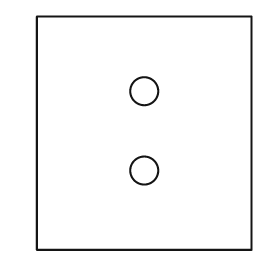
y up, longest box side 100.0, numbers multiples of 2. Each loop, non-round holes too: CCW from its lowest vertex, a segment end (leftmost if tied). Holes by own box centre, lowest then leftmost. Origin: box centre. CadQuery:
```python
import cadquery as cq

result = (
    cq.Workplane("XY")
    .moveTo(-46.0, -50.0)
    .lineTo(46.0, -50.0)
    .lineTo(46.0, 50.0)
    .lineTo(-46.0, 50.0)
    .close()
    .moveTo(0.0, -16.0)
    .circle(6.0)
    .moveTo(0.0, 18.0)
    .circle(6.0)
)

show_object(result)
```